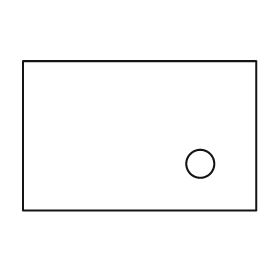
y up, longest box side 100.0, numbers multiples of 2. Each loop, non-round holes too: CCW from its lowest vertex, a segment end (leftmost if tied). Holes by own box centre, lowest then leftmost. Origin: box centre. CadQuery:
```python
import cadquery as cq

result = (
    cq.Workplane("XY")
    .moveTo(-50.0, -32.0)
    .lineTo(50.0, -32.0)
    .lineTo(50.0, 32.0)
    .lineTo(-50.0, 32.0)
    .close()
    .moveTo(26.0, -12.0)
    .circle(6.0)
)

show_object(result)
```